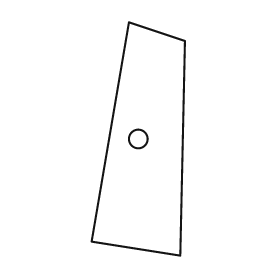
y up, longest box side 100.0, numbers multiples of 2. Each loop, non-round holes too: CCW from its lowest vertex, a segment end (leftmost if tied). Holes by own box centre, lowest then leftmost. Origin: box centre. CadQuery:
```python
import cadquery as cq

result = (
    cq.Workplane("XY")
    .moveTo(18.0, -50.0)
    .lineTo(20.0, 42.0)
    .lineTo(-4.0, 50.0)
    .lineTo(-20.0, -44.0)
    .close()
    .moveTo(0.0, 0.0)
    .circle(4.0)
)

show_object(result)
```